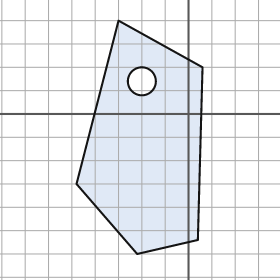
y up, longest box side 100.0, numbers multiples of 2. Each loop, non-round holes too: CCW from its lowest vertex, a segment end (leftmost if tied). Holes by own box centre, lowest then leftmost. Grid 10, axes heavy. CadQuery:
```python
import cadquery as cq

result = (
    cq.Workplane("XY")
    .moveTo(-22.0, -60.0)
    .lineTo(4.0, -54.0)
    .lineTo(6.0, 20.0)
    .lineTo(-30.0, 40.0)
    .lineTo(-48.0, -30.0)
    .close()
    .moveTo(-20.0, 14.0)
    .circle(6.0)
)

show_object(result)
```